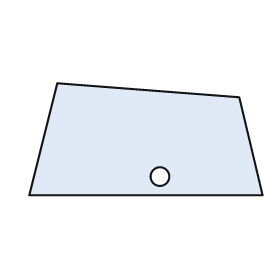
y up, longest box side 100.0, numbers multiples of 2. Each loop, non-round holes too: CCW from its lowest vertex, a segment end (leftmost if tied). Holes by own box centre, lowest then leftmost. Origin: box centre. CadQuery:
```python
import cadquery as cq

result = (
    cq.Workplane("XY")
    .moveTo(-50.0, -24.0)
    .lineTo(50.0, -24.0)
    .lineTo(40.0, 18.0)
    .lineTo(-38.0, 24.0)
    .close()
    .moveTo(6.0, -16.0)
    .circle(4.0)
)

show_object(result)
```